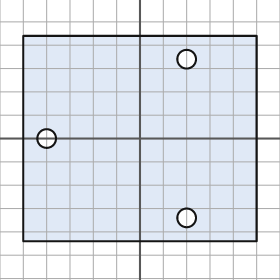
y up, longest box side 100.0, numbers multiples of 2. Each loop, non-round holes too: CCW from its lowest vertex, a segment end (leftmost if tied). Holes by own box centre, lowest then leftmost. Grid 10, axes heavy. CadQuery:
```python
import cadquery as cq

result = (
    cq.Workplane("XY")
    .moveTo(-50.0, -44.0)
    .lineTo(50.0, -44.0)
    .lineTo(50.0, 44.0)
    .lineTo(-50.0, 44.0)
    .close()
    .moveTo(20.0, -34.0)
    .circle(4.0)
    .moveTo(-40.0, 0.0)
    .circle(4.0)
    .moveTo(20.0, 34.0)
    .circle(4.0)
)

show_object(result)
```